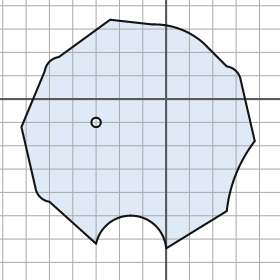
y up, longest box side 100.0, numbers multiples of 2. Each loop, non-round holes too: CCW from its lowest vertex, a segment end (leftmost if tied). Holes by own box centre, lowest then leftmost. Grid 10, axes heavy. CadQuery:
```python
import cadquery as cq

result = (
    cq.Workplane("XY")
    .moveTo(0.0, -64.0)
    .lineTo(26.0, -48.0)
    .threePointArc((30.0, -32.0), (38.0, -18.0))
    .lineTo(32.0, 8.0)
    .threePointArc((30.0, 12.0), (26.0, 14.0))
    .lineTo(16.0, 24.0)
    .threePointArc((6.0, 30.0), (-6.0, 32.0))
    .lineTo(-24.0, 34.0)
    .lineTo(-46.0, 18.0)
    .threePointArc((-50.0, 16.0), (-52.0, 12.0))
    .lineTo(-62.0, -12.0)
    .lineTo(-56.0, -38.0)
    .threePointArc((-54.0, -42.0), (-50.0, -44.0))
    .lineTo(-30.0, -62.0)
    .threePointArc((-14.0, -50.0), (0.0, -64.0))
    .close()
    .moveTo(-30.0, -10.0)
    .circle(2.0)
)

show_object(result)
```